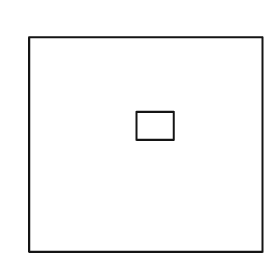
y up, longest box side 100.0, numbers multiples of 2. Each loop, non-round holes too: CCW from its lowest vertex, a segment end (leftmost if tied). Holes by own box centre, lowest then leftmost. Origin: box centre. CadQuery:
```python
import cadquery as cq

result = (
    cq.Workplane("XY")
    .moveTo(-50.0, -46.0)
    .lineTo(50.0, -46.0)
    .lineTo(50.0, 46.0)
    .lineTo(-50.0, 46.0)
    .close()
    .moveTo(-4.0, 2.0)
    .lineTo(12.0, 2.0)
    .lineTo(12.0, 14.0)
    .lineTo(-4.0, 14.0)
    .close()
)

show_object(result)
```